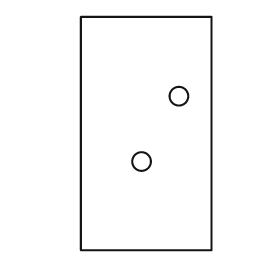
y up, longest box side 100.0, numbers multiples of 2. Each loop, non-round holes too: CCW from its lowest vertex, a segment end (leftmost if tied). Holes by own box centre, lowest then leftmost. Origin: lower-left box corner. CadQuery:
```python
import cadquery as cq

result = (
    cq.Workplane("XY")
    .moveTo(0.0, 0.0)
    .lineTo(56.0, 0.0)
    .lineTo(56.0, 100.0)
    .lineTo(0.0, 100.0)
    .close()
    .moveTo(26.0, 38.0)
    .circle(4.0)
    .moveTo(42.0, 66.0)
    .circle(4.0)
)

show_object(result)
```